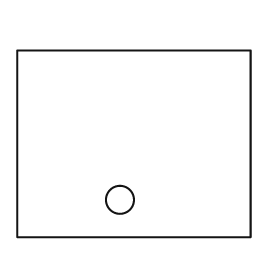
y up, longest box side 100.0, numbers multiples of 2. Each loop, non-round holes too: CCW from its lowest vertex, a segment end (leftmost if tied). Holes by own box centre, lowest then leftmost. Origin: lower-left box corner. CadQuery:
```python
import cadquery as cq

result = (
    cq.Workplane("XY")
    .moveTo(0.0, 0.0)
    .lineTo(100.0, 0.0)
    .lineTo(100.0, 80.0)
    .lineTo(0.0, 80.0)
    .close()
    .moveTo(44.0, 16.0)
    .circle(6.0)
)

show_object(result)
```